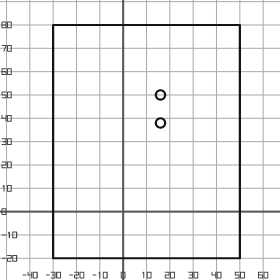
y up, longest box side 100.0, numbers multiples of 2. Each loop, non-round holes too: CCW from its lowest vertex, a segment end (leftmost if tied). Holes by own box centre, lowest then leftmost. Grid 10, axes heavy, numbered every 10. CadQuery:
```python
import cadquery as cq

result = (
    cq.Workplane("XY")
    .moveTo(-30.0, -20.0)
    .lineTo(50.0, -20.0)
    .lineTo(50.0, 80.0)
    .lineTo(-30.0, 80.0)
    .close()
    .moveTo(16.0, 38.0)
    .circle(2.0)
    .moveTo(16.0, 50.0)
    .circle(2.0)
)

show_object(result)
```